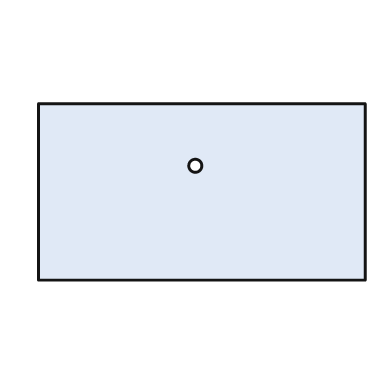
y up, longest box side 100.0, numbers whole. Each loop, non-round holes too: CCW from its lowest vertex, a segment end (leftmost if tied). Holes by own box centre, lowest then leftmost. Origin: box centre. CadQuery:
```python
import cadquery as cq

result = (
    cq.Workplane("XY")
    .moveTo(-50.0, -27.0)
    .lineTo(50.0, -27.0)
    .lineTo(50.0, 27.0)
    .lineTo(-50.0, 27.0)
    .close()
    .moveTo(-2.0, 8.0)
    .circle(2.0)
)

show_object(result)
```